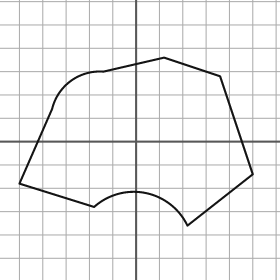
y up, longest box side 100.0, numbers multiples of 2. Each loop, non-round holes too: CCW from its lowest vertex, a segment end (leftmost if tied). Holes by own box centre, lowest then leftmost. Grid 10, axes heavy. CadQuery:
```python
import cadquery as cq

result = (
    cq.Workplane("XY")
    .moveTo(22.0, -36.0)
    .lineTo(50.0, -14.0)
    .lineTo(36.0, 28.0)
    .lineTo(12.0, 36.0)
    .lineTo(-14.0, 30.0)
    .threePointArc((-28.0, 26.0), (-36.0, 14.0))
    .lineTo(-50.0, -18.0)
    .lineTo(-18.0, -28.0)
    .threePointArc((4.0, -22.0), (22.0, -36.0))
    .close()
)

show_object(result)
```